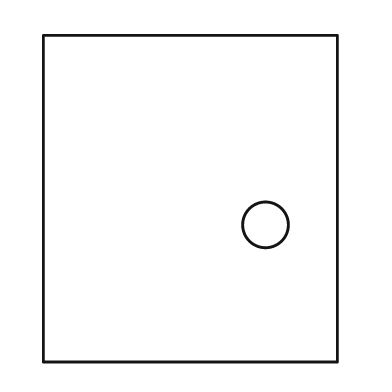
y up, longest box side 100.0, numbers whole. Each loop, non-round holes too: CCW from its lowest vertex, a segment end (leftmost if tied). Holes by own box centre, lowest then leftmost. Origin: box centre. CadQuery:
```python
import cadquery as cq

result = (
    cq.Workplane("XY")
    .moveTo(-45.0, -50.0)
    .lineTo(45.0, -50.0)
    .lineTo(45.0, 50.0)
    .lineTo(-45.0, 50.0)
    .close()
    .moveTo(23.0, -8.0)
    .circle(7.0)
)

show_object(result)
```